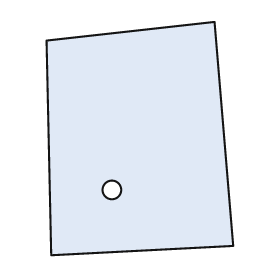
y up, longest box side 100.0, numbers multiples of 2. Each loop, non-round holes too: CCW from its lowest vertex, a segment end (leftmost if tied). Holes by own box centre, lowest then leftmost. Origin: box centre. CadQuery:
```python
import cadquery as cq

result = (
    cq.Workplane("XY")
    .moveTo(-38.0, -50.0)
    .lineTo(40.0, -46.0)
    .lineTo(32.0, 50.0)
    .lineTo(-40.0, 42.0)
    .close()
    .moveTo(-12.0, -22.0)
    .circle(4.0)
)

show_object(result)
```